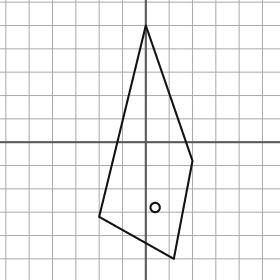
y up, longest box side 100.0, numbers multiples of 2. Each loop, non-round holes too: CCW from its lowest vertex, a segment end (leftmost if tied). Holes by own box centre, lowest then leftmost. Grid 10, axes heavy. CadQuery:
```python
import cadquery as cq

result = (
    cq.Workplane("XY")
    .moveTo(12.0, -50.0)
    .lineTo(20.0, -8.0)
    .lineTo(0.0, 50.0)
    .lineTo(-20.0, -32.0)
    .close()
    .moveTo(4.0, -28.0)
    .circle(2.0)
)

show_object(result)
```